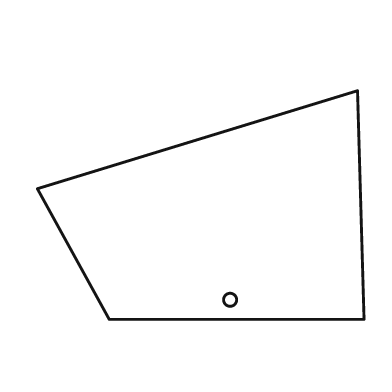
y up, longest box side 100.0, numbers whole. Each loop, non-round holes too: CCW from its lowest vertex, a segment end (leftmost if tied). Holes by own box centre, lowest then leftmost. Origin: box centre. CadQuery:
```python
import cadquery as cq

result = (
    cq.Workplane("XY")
    .moveTo(-28.0, -35.0)
    .lineTo(50.0, -35.0)
    .lineTo(48.0, 35.0)
    .lineTo(-50.0, 5.0)
    .close()
    .moveTo(9.0, -29.0)
    .circle(2.0)
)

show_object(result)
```